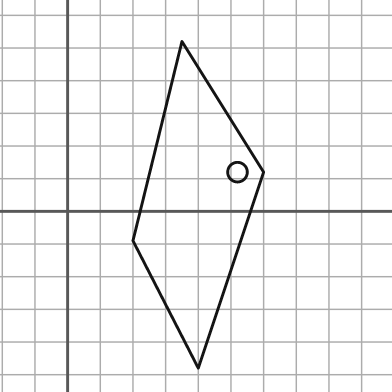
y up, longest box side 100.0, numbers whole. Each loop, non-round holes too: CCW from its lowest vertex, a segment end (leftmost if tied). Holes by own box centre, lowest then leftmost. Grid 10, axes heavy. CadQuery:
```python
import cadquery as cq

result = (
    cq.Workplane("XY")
    .moveTo(40.0, -48.0)
    .lineTo(60.0, 12.0)
    .lineTo(35.0, 52.0)
    .lineTo(20.0, -9.0)
    .close()
    .moveTo(52.0, 12.0)
    .circle(3.0)
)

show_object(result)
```